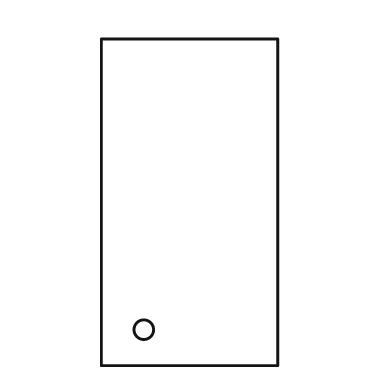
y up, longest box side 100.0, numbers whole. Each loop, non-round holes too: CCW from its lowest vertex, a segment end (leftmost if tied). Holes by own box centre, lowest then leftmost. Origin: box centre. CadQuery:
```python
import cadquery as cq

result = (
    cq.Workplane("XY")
    .moveTo(-27.0, -50.0)
    .lineTo(27.0, -50.0)
    .lineTo(27.0, 50.0)
    .lineTo(-27.0, 50.0)
    .close()
    .moveTo(-14.0, -39.0)
    .circle(3.0)
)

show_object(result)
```